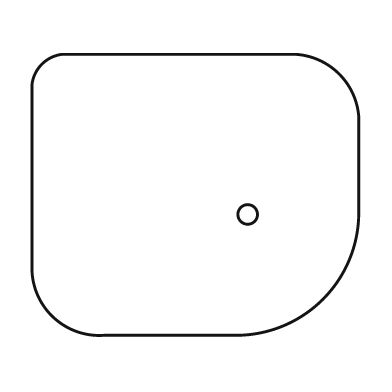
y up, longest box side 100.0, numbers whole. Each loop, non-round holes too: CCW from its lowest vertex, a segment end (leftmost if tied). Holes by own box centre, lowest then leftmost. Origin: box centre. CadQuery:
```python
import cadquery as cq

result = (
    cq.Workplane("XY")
    .moveTo(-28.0, -43.0)
    .lineTo(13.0, -43.0)
    .threePointArc((39.0, -32.0), (50.0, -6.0))
    .lineTo(50.0, 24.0)
    .threePointArc((44.0, 37.0), (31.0, 43.0))
    .lineTo(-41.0, 43.0)
    .threePointArc((-47.0, 40.0), (-50.0, 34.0))
    .lineTo(-50.0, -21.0)
    .threePointArc((-44.0, -37.0), (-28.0, -43.0))
    .close()
    .moveTo(16.0, -6.0)
    .circle(3.0)
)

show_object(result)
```